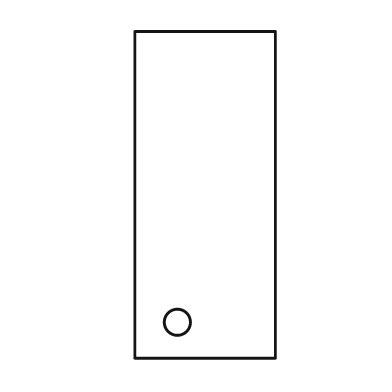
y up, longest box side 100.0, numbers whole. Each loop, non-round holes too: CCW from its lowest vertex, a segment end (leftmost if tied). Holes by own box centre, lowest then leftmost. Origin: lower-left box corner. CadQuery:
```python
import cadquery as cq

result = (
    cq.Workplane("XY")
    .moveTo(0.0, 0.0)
    .lineTo(43.0, 0.0)
    .lineTo(43.0, 100.0)
    .lineTo(0.0, 100.0)
    .close()
    .moveTo(13.0, 11.0)
    .circle(4.0)
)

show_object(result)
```